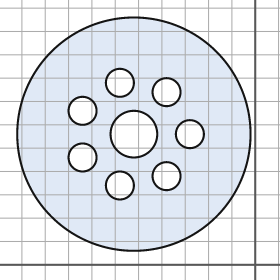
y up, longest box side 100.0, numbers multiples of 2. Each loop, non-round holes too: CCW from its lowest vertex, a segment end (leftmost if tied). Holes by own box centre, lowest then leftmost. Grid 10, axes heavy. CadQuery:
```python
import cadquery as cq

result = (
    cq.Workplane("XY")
    .moveTo(-52.0, 56.0)
    .circle(50.0)
    .moveTo(-58.0, 34.0)
    .circle(6.0)
    .moveTo(-38.0, 38.0)
    .circle(6.0)
    .moveTo(-74.0, 46.0)
    .circle(6.0)
    .moveTo(-52.0, 56.0)
    .circle(10.0)
    .moveTo(-28.0, 56.0)
    .circle(6.0)
    .moveTo(-74.0, 66.0)
    .circle(6.0)
    .moveTo(-38.0, 74.0)
    .circle(6.0)
    .moveTo(-58.0, 78.0)
    .circle(6.0)
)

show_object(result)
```